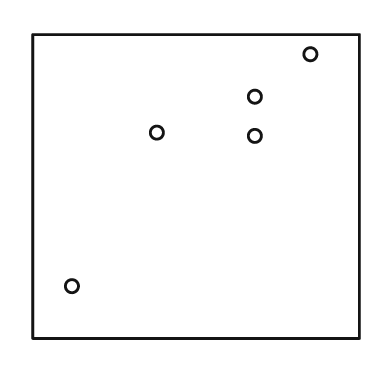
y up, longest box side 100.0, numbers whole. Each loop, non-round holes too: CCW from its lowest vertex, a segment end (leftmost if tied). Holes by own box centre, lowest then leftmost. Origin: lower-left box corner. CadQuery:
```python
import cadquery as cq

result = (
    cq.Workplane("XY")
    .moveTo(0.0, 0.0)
    .lineTo(100.0, 0.0)
    .lineTo(100.0, 93.0)
    .lineTo(0.0, 93.0)
    .close()
    .moveTo(12.0, 16.0)
    .circle(2.0)
    .moveTo(68.0, 62.0)
    .circle(2.0)
    .moveTo(38.0, 63.0)
    .circle(2.0)
    .moveTo(68.0, 74.0)
    .circle(2.0)
    .moveTo(85.0, 87.0)
    .circle(2.0)
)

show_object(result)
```